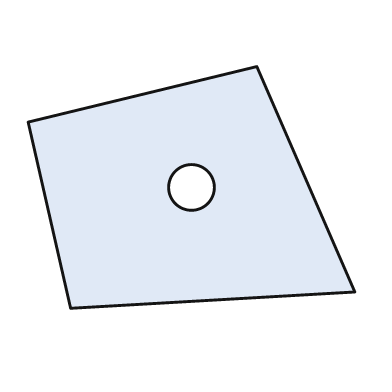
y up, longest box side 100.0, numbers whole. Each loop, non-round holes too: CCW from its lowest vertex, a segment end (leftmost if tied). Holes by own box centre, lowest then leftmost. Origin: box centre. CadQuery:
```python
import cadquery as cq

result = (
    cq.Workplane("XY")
    .moveTo(-37.0, -37.0)
    .lineTo(50.0, -32.0)
    .lineTo(20.0, 37.0)
    .lineTo(-50.0, 20.0)
    .close()
    .moveTo(0.0, 0.0)
    .circle(7.0)
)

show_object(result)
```